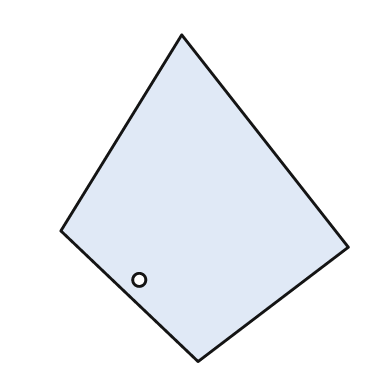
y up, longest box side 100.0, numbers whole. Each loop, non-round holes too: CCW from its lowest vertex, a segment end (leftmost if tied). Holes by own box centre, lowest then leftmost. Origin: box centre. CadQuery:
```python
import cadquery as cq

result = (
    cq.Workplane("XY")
    .moveTo(-2.0, -50.0)
    .lineTo(44.0, -15.0)
    .lineTo(-7.0, 50.0)
    .lineTo(-44.0, -10.0)
    .close()
    .moveTo(-20.0, -25.0)
    .circle(2.0)
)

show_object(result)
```